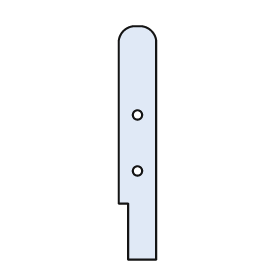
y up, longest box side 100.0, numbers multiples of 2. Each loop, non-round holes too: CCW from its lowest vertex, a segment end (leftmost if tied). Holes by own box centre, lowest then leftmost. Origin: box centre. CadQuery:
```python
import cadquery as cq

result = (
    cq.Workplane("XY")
    .moveTo(-4.0, -50.0)
    .lineTo(8.0, -50.0)
    .lineTo(8.0, 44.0)
    .threePointArc((6.0, 48.0), (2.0, 50.0))
    .lineTo(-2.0, 50.0)
    .threePointArc((-6.0, 48.0), (-8.0, 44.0))
    .lineTo(-8.0, -26.0)
    .lineTo(-4.0, -26.0)
    .close()
    .moveTo(0.0, -12.0)
    .circle(2.0)
    .moveTo(0.0, 12.0)
    .circle(2.0)
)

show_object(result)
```